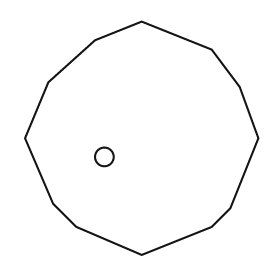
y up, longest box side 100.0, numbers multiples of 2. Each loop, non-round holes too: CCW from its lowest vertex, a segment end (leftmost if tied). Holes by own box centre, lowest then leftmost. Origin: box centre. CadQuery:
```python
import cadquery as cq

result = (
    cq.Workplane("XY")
    .moveTo(0.0, -50.0)
    .lineTo(30.0, -38.0)
    .lineTo(38.0, -30.0)
    .lineTo(50.0, 0.0)
    .lineTo(42.0, 22.0)
    .lineTo(30.0, 38.0)
    .lineTo(0.0, 50.0)
    .lineTo(-20.0, 42.0)
    .lineTo(-40.0, 24.0)
    .lineTo(-50.0, 0.0)
    .lineTo(-38.0, -28.0)
    .lineTo(-28.0, -38.0)
    .close()
    .moveTo(-16.0, -8.0)
    .circle(4.0)
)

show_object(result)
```